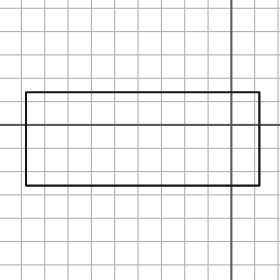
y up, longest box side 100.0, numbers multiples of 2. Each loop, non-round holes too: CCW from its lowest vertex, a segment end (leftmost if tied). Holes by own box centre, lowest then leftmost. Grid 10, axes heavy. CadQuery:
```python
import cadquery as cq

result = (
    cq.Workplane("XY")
    .moveTo(-88.0, -26.0)
    .lineTo(12.0, -26.0)
    .lineTo(12.0, 14.0)
    .lineTo(-88.0, 14.0)
    .close()
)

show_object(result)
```